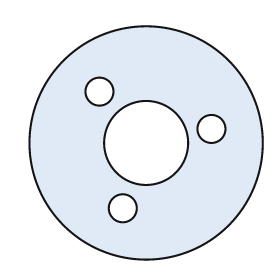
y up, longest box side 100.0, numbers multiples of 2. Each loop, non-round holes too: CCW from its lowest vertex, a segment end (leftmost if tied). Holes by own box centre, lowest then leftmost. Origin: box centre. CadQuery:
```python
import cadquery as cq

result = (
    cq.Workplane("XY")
    .moveTo(0.0, 0.0)
    .circle(50.0)
    .moveTo(-10.0, -28.0)
    .circle(6.0)
    .moveTo(0.0, 0.0)
    .circle(18.0)
    .moveTo(28.0, 6.0)
    .circle(6.0)
    .moveTo(-20.0, 22.0)
    .circle(6.0)
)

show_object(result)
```